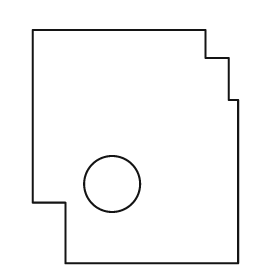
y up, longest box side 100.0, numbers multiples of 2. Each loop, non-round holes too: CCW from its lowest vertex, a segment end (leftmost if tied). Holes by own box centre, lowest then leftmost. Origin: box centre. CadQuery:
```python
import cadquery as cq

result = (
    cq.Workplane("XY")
    .moveTo(-30.0, -50.0)
    .lineTo(44.0, -50.0)
    .lineTo(44.0, 20.0)
    .lineTo(40.0, 20.0)
    .lineTo(40.0, 38.0)
    .lineTo(30.0, 38.0)
    .lineTo(30.0, 50.0)
    .lineTo(-44.0, 50.0)
    .lineTo(-44.0, -24.0)
    .lineTo(-30.0, -24.0)
    .close()
    .moveTo(-10.0, -16.0)
    .circle(12.0)
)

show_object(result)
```